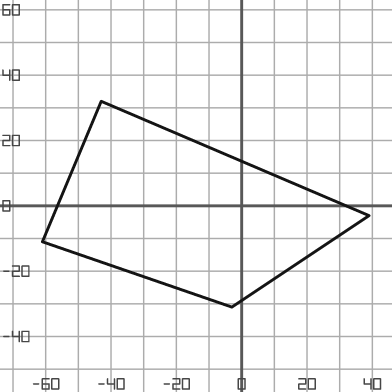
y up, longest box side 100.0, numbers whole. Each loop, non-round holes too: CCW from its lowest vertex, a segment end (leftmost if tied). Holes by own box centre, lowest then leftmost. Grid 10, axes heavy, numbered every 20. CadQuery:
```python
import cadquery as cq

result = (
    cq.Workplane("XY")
    .moveTo(-3.0, -31.0)
    .lineTo(39.0, -3.0)
    .lineTo(-43.0, 32.0)
    .lineTo(-61.0, -11.0)
    .close()
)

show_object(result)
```